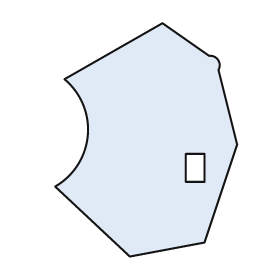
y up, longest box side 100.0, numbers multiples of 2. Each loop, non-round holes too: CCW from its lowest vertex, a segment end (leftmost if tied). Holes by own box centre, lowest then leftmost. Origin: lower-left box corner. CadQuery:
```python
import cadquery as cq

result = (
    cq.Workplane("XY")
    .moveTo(32.0, 0.0)
    .lineTo(64.0, 6.0)
    .lineTo(78.0, 48.0)
    .lineTo(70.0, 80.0)
    .threePointArc((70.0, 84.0), (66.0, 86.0))
    .lineTo(46.0, 100.0)
    .lineTo(4.0, 76.0)
    .threePointArc((14.0, 52.0), (0.0, 30.0))
    .close()
    .moveTo(56.0, 32.0)
    .lineTo(64.0, 32.0)
    .lineTo(64.0, 44.0)
    .lineTo(56.0, 44.0)
    .close()
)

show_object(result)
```